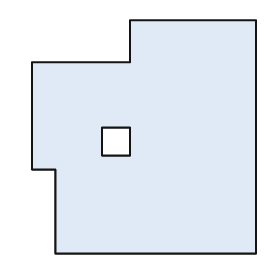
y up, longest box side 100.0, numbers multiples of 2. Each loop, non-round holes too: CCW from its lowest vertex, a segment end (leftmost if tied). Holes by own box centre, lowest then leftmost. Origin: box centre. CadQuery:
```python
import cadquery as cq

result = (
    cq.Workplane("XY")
    .moveTo(-38.0, -50.0)
    .lineTo(48.0, -50.0)
    .lineTo(48.0, 50.0)
    .lineTo(-6.0, 50.0)
    .lineTo(-6.0, 32.0)
    .lineTo(-48.0, 32.0)
    .lineTo(-48.0, -14.0)
    .lineTo(-38.0, -14.0)
    .close()
    .moveTo(-18.0, -8.0)
    .lineTo(-6.0, -8.0)
    .lineTo(-6.0, 4.0)
    .lineTo(-18.0, 4.0)
    .close()
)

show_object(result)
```